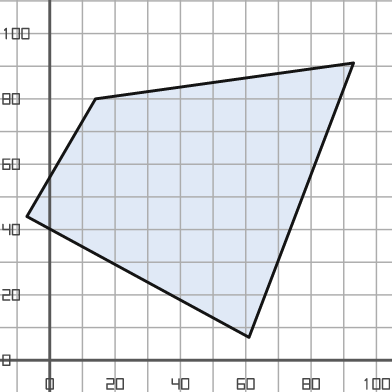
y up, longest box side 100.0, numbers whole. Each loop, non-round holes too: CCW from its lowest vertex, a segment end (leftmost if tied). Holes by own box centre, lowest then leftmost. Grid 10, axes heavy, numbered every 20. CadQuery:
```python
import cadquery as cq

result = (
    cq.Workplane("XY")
    .moveTo(61.0, 7.0)
    .lineTo(93.0, 91.0)
    .lineTo(14.0, 80.0)
    .lineTo(-7.0, 44.0)
    .close()
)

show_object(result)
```